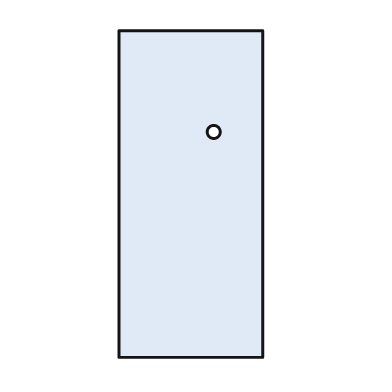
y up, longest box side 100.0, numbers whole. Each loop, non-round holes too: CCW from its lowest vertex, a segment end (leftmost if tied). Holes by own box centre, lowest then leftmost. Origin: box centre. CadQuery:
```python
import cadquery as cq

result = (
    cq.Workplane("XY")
    .moveTo(-22.0, -50.0)
    .lineTo(22.0, -50.0)
    .lineTo(22.0, 50.0)
    .lineTo(-22.0, 50.0)
    .close()
    .moveTo(7.0, 19.0)
    .circle(2.0)
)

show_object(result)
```